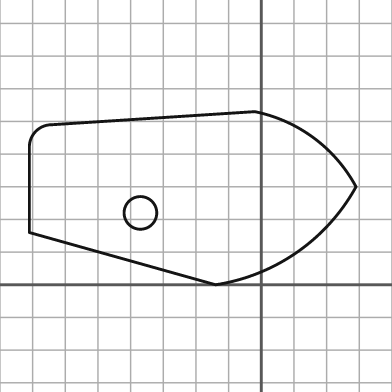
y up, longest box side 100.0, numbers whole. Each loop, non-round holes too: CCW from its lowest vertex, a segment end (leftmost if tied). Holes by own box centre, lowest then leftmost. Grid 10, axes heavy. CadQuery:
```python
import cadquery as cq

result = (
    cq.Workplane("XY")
    .moveTo(-14.0, 0.0)
    .threePointArc((11.0, 10.0), (29.0, 30.0))
    .threePointArc((16.0, 45.0), (-2.0, 53.0))
    .lineTo(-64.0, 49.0)
    .threePointArc((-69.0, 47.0), (-71.0, 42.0))
    .lineTo(-71.0, 16.0)
    .close()
    .moveTo(-37.0, 22.0)
    .circle(5.0)
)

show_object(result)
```